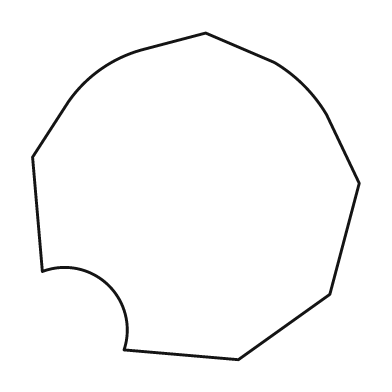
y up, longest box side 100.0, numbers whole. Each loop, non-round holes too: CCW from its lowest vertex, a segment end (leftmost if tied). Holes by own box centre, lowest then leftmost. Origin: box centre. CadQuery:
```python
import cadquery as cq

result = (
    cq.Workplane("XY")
    .moveTo(13.0, -50.0)
    .lineTo(41.0, -30.0)
    .lineTo(50.0, 4.0)
    .lineTo(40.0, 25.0)
    .threePointArc((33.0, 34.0), (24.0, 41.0))
    .lineTo(3.0, 50.0)
    .lineTo(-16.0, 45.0)
    .threePointArc((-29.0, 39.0), (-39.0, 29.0))
    .lineTo(-50.0, 12.0)
    .lineTo(-47.0, -23.0)
    .threePointArc((-27.0, -27.0), (-22.0, -47.0))
    .close()
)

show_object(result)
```